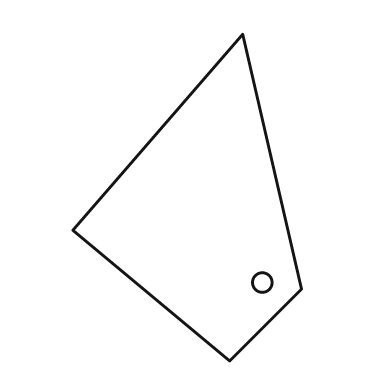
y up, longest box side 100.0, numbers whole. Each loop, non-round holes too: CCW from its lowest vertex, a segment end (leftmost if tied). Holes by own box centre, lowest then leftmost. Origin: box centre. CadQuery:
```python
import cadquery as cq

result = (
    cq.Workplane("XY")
    .moveTo(13.0, -50.0)
    .lineTo(35.0, -28.0)
    .lineTo(17.0, 50.0)
    .lineTo(-35.0, -10.0)
    .close()
    .moveTo(23.0, -26.0)
    .circle(3.0)
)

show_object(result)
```